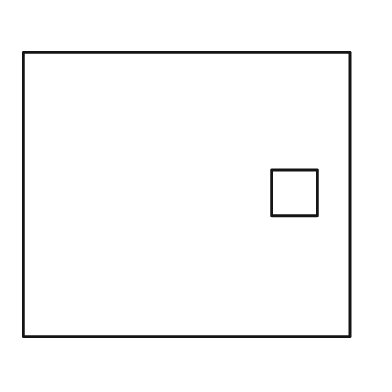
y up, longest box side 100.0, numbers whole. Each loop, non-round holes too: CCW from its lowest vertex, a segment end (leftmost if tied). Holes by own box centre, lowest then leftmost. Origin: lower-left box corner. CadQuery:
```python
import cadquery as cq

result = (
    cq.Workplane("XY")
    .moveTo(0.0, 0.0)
    .lineTo(100.0, 0.0)
    .lineTo(100.0, 87.0)
    .lineTo(0.0, 87.0)
    .close()
    .moveTo(76.0, 37.0)
    .lineTo(90.0, 37.0)
    .lineTo(90.0, 51.0)
    .lineTo(76.0, 51.0)
    .close()
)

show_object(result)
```